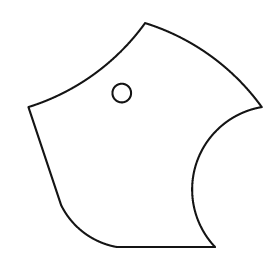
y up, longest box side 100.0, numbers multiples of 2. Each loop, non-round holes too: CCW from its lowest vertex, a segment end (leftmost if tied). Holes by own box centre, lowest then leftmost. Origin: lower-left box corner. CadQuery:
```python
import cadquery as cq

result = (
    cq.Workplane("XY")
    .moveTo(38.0, 0.0)
    .lineTo(80.0, 0.0)
    .threePointArc((72.0, 36.0), (100.0, 60.0))
    .threePointArc((78.0, 82.0), (50.0, 96.0))
    .threePointArc((28.0, 74.0), (0.0, 60.0))
    .lineTo(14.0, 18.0)
    .threePointArc((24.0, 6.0), (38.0, 0.0))
    .close()
    .moveTo(40.0, 66.0)
    .circle(4.0)
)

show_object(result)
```